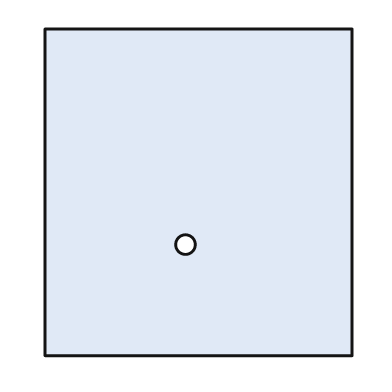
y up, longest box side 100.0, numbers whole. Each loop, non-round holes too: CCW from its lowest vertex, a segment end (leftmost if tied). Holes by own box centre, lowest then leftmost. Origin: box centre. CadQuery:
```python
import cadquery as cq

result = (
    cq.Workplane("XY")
    .moveTo(-47.0, -50.0)
    .lineTo(47.0, -50.0)
    .lineTo(47.0, 50.0)
    .lineTo(-47.0, 50.0)
    .close()
    .moveTo(-4.0, -16.0)
    .circle(3.0)
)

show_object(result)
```